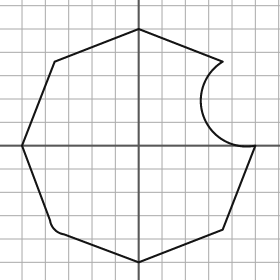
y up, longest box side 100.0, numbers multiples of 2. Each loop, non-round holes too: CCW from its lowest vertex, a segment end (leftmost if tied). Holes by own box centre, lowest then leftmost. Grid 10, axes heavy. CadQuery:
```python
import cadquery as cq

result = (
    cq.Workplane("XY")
    .moveTo(0.0, -50.0)
    .lineTo(36.0, -36.0)
    .lineTo(50.0, 0.0)
    .threePointArc((28.0, 12.0), (36.0, 36.0))
    .lineTo(0.0, 50.0)
    .lineTo(-36.0, 36.0)
    .lineTo(-50.0, 0.0)
    .lineTo(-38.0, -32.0)
    .threePointArc((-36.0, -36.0), (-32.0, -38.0))
    .close()
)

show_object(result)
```